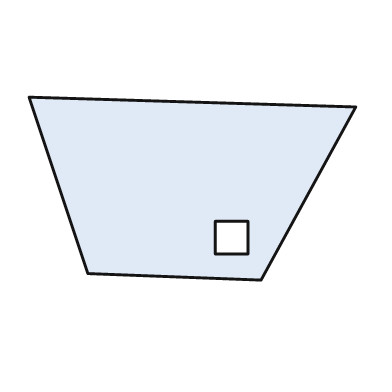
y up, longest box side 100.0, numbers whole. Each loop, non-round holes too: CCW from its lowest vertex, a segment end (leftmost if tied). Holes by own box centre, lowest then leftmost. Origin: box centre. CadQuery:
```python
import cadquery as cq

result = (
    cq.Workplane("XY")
    .moveTo(21.0, -28.0)
    .lineTo(50.0, 25.0)
    .lineTo(-50.0, 28.0)
    .lineTo(-32.0, -26.0)
    .close()
    .moveTo(7.0, -20.0)
    .lineTo(17.0, -20.0)
    .lineTo(17.0, -10.0)
    .lineTo(7.0, -10.0)
    .close()
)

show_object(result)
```